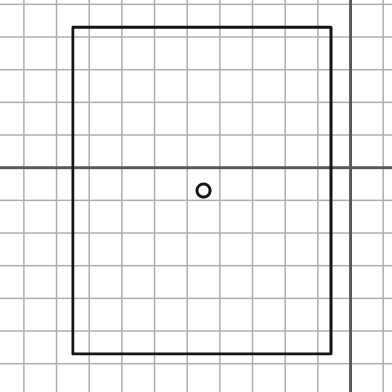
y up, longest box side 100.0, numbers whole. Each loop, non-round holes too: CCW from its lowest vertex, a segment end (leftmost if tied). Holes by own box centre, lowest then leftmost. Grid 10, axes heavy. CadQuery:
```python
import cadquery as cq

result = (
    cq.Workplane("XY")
    .moveTo(-85.0, -57.0)
    .lineTo(-6.0, -57.0)
    .lineTo(-6.0, 43.0)
    .lineTo(-85.0, 43.0)
    .close()
    .moveTo(-45.0, -7.0)
    .circle(2.0)
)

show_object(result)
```